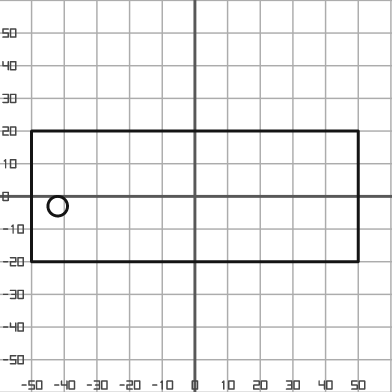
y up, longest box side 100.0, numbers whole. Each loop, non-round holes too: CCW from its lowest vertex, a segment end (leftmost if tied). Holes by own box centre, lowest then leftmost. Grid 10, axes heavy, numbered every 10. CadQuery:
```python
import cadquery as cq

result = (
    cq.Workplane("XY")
    .moveTo(-50.0, -20.0)
    .lineTo(50.0, -20.0)
    .lineTo(50.0, 20.0)
    .lineTo(-50.0, 20.0)
    .close()
    .moveTo(-42.0, -3.0)
    .circle(3.0)
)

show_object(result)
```